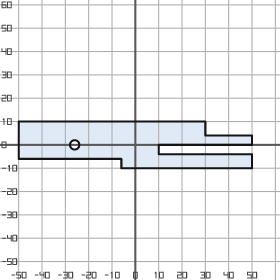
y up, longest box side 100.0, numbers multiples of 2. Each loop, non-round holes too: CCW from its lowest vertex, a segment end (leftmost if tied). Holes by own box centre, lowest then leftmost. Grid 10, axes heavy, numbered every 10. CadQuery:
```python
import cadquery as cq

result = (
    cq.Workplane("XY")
    .moveTo(-6.0, -10.0)
    .lineTo(50.0, -10.0)
    .lineTo(50.0, -4.0)
    .lineTo(10.0, -4.0)
    .lineTo(10.0, 0.0)
    .lineTo(50.0, 0.0)
    .lineTo(50.0, 4.0)
    .lineTo(30.0, 4.0)
    .lineTo(30.0, 10.0)
    .lineTo(-50.0, 10.0)
    .lineTo(-50.0, -6.0)
    .lineTo(-6.0, -6.0)
    .close()
    .moveTo(-26.0, 0.0)
    .circle(2.0)
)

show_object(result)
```